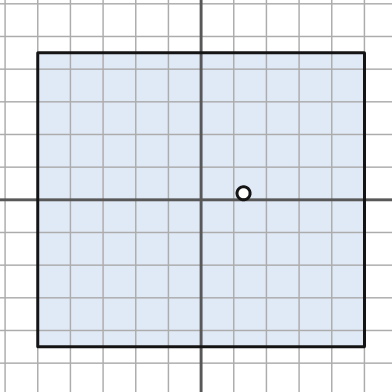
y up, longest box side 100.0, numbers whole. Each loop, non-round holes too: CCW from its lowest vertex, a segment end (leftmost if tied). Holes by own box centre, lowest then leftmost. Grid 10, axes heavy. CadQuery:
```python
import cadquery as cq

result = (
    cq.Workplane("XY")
    .moveTo(-50.0, -45.0)
    .lineTo(50.0, -45.0)
    .lineTo(50.0, 45.0)
    .lineTo(-50.0, 45.0)
    .close()
    .moveTo(13.0, 2.0)
    .circle(2.0)
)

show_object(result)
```